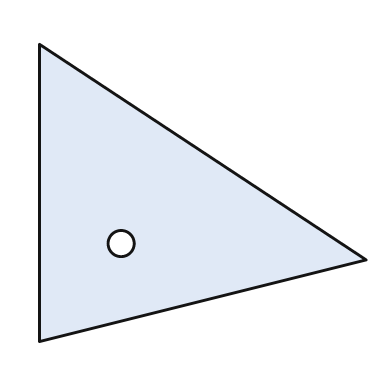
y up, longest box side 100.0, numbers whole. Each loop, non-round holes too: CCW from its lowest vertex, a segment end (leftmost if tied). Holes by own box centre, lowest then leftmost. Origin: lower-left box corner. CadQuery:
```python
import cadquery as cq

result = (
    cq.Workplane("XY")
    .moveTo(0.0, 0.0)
    .lineTo(100.0, 25.0)
    .lineTo(0.0, 91.0)
    .close()
    .moveTo(25.0, 30.0)
    .circle(4.0)
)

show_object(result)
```